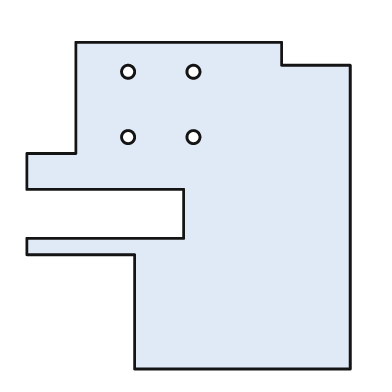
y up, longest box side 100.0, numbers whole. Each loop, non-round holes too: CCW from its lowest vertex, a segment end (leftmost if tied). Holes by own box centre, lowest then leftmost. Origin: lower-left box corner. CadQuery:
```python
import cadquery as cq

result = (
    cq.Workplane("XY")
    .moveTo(33.0, 0.0)
    .lineTo(99.0, 0.0)
    .lineTo(99.0, 93.0)
    .lineTo(78.0, 93.0)
    .lineTo(78.0, 100.0)
    .lineTo(15.0, 100.0)
    .lineTo(15.0, 66.0)
    .lineTo(0.0, 66.0)
    .lineTo(0.0, 55.0)
    .lineTo(48.0, 55.0)
    .lineTo(48.0, 40.0)
    .lineTo(0.0, 40.0)
    .lineTo(0.0, 35.0)
    .lineTo(33.0, 35.0)
    .close()
    .moveTo(31.0, 71.0)
    .circle(2.0)
    .moveTo(51.0, 71.0)
    .circle(2.0)
    .moveTo(31.0, 91.0)
    .circle(2.0)
    .moveTo(51.0, 91.0)
    .circle(2.0)
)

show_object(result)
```